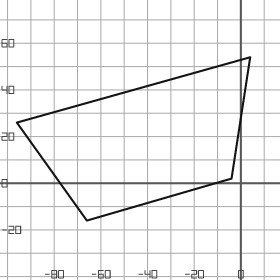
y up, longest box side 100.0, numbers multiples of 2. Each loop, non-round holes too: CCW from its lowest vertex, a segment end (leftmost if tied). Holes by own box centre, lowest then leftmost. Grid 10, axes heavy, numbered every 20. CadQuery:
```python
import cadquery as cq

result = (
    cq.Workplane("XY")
    .moveTo(-66.0, -16.0)
    .lineTo(-4.0, 2.0)
    .lineTo(4.0, 54.0)
    .lineTo(-96.0, 26.0)
    .close()
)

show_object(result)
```